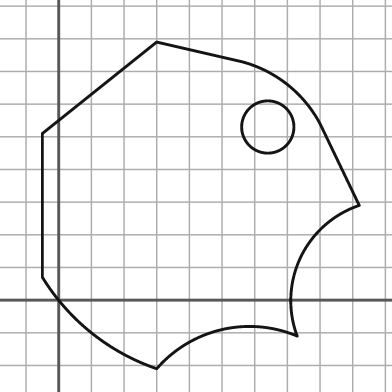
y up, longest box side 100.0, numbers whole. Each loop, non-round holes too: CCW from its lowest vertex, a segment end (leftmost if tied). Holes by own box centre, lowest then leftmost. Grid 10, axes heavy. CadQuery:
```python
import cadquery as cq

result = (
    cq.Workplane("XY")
    .moveTo(30.0, -21.0)
    .threePointArc((50.0, -9.0), (73.0, -11.0))
    .threePointArc((74.0, 13.0), (92.0, 29.0))
    .lineTo(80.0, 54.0)
    .threePointArc((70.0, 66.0), (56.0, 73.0))
    .lineTo(30.0, 79.0)
    .lineTo(-5.0, 51.0)
    .lineTo(-5.0, 7.0)
    .threePointArc((10.0, -10.0), (30.0, -21.0))
    .close()
    .moveTo(64.0, 53.0)
    .circle(8.0)
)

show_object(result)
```